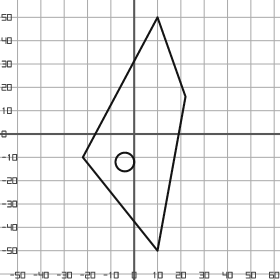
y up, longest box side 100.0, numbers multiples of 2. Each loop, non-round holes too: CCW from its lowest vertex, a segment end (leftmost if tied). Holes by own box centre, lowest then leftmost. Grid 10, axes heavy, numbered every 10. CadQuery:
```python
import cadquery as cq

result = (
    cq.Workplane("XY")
    .moveTo(10.0, -50.0)
    .lineTo(22.0, 16.0)
    .lineTo(10.0, 50.0)
    .lineTo(-22.0, -10.0)
    .close()
    .moveTo(-4.0, -12.0)
    .circle(4.0)
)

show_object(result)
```